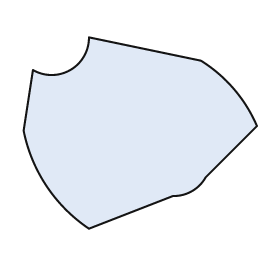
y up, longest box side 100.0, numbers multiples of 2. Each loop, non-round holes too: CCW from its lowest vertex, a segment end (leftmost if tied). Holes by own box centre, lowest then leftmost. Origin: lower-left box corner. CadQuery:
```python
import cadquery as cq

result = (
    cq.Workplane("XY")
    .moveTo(28.0, 0.0)
    .lineTo(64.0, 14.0)
    .threePointArc((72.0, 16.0), (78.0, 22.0))
    .lineTo(100.0, 44.0)
    .threePointArc((90.0, 60.0), (76.0, 72.0))
    .lineTo(28.0, 82.0)
    .threePointArc((20.0, 68.0), (4.0, 68.0))
    .lineTo(0.0, 42.0)
    .threePointArc((10.0, 18.0), (28.0, 0.0))
    .close()
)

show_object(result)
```